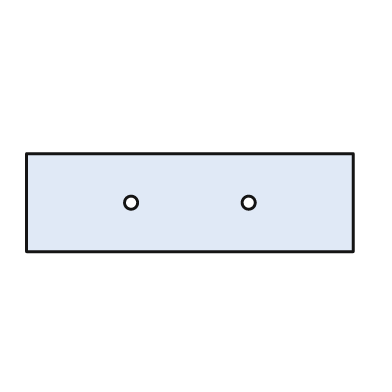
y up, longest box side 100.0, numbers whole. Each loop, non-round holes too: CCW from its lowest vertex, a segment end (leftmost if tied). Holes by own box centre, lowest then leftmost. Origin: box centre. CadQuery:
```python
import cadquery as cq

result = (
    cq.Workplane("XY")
    .moveTo(-50.0, -15.0)
    .lineTo(50.0, -15.0)
    .lineTo(50.0, 15.0)
    .lineTo(-50.0, 15.0)
    .close()
    .moveTo(-18.0, 0.0)
    .circle(2.0)
    .moveTo(18.0, 0.0)
    .circle(2.0)
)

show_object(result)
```